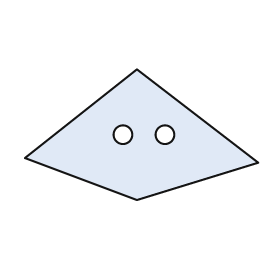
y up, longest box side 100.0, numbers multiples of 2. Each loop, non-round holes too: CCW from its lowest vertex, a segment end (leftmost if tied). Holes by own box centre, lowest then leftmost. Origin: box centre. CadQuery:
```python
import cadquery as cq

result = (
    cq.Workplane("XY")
    .moveTo(-2.0, -28.0)
    .lineTo(50.0, -12.0)
    .lineTo(-2.0, 28.0)
    .lineTo(-50.0, -10.0)
    .close()
    .moveTo(-8.0, 0.0)
    .circle(4.0)
    .moveTo(10.0, 0.0)
    .circle(4.0)
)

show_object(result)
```